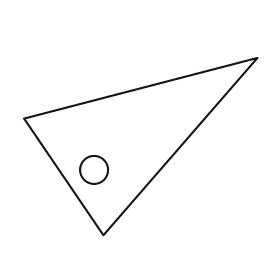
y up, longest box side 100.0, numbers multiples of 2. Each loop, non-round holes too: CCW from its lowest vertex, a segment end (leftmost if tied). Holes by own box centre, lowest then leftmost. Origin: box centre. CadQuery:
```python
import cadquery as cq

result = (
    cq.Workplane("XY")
    .moveTo(-16.0, -38.0)
    .lineTo(50.0, 38.0)
    .lineTo(-50.0, 12.0)
    .close()
    .moveTo(-20.0, -10.0)
    .circle(6.0)
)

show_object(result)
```